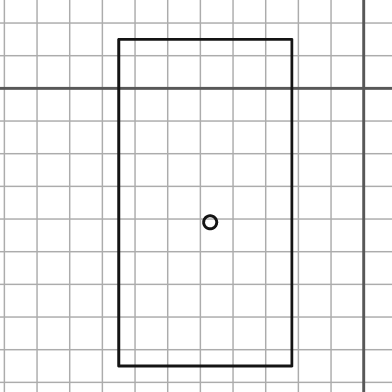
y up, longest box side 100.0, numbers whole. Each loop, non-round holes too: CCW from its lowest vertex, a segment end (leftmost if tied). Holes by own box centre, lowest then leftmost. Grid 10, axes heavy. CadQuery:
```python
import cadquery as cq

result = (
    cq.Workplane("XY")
    .moveTo(-75.0, -85.0)
    .lineTo(-22.0, -85.0)
    .lineTo(-22.0, 15.0)
    .lineTo(-75.0, 15.0)
    .close()
    .moveTo(-47.0, -41.0)
    .circle(2.0)
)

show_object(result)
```